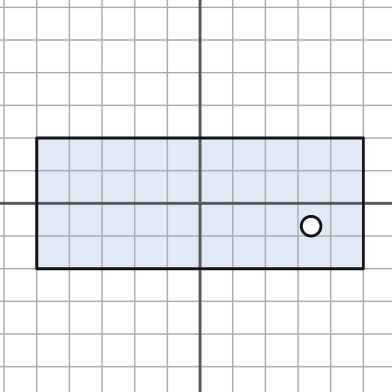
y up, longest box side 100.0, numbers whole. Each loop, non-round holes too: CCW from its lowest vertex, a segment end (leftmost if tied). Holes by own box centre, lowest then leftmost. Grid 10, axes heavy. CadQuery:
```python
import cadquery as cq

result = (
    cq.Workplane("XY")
    .moveTo(-50.0, -20.0)
    .lineTo(50.0, -20.0)
    .lineTo(50.0, 20.0)
    .lineTo(-50.0, 20.0)
    .close()
    .moveTo(34.0, -7.0)
    .circle(3.0)
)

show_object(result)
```